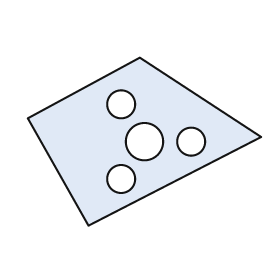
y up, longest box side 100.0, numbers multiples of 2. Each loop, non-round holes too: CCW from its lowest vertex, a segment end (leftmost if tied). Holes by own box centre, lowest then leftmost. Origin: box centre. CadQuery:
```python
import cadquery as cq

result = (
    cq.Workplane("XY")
    .moveTo(-24.0, -36.0)
    .lineTo(50.0, 2.0)
    .lineTo(-2.0, 36.0)
    .lineTo(-50.0, 10.0)
    .close()
    .moveTo(-10.0, -16.0)
    .circle(6.0)
    .moveTo(0.0, 0.0)
    .circle(8.0)
    .moveTo(20.0, 0.0)
    .circle(6.0)
    .moveTo(-10.0, 16.0)
    .circle(6.0)
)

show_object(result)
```